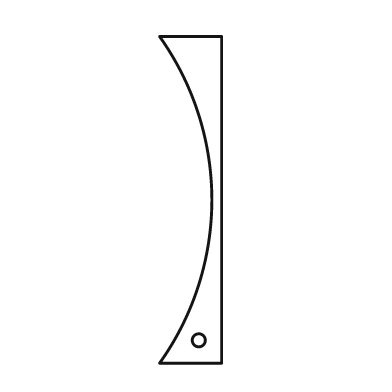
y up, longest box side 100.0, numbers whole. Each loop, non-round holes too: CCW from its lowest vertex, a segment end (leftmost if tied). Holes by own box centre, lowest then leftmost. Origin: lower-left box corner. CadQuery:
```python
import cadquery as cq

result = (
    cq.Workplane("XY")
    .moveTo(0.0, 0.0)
    .lineTo(19.0, 0.0)
    .lineTo(19.0, 100.0)
    .lineTo(0.0, 100.0)
    .threePointArc((16.0, 50.0), (0.0, 0.0))
    .close()
    .moveTo(12.0, 7.0)
    .circle(2.0)
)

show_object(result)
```